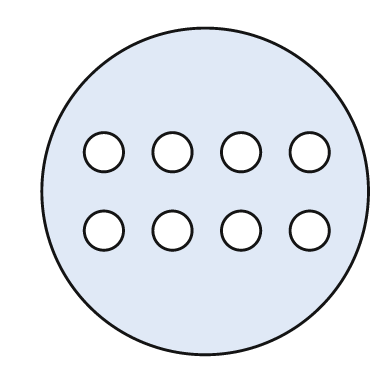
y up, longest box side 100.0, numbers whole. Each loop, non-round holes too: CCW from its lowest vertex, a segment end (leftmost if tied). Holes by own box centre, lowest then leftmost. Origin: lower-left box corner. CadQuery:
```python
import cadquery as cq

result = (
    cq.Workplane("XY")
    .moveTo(50.0, 50.0)
    .circle(50.0)
    .moveTo(19.0, 38.0)
    .circle(6.0)
    .moveTo(40.0, 38.0)
    .circle(6.0)
    .moveTo(61.0, 38.0)
    .circle(6.0)
    .moveTo(82.0, 38.0)
    .circle(6.0)
    .moveTo(19.0, 62.0)
    .circle(6.0)
    .moveTo(40.0, 62.0)
    .circle(6.0)
    .moveTo(61.0, 62.0)
    .circle(6.0)
    .moveTo(82.0, 62.0)
    .circle(6.0)
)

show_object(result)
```